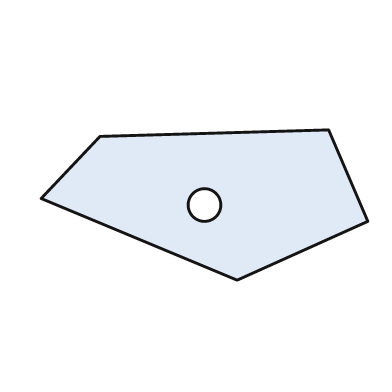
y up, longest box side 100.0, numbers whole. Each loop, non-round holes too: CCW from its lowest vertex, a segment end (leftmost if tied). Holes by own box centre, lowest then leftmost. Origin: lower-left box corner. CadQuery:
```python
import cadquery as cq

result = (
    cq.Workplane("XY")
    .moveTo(60.0, 0.0)
    .lineTo(100.0, 18.0)
    .lineTo(88.0, 46.0)
    .lineTo(18.0, 44.0)
    .lineTo(0.0, 25.0)
    .close()
    .moveTo(50.0, 23.0)
    .circle(5.0)
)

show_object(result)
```